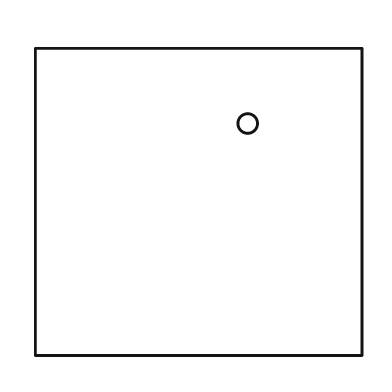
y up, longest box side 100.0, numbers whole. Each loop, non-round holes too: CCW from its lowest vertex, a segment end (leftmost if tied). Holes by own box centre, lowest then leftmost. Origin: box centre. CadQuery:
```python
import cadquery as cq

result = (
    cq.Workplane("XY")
    .moveTo(-50.0, -47.0)
    .lineTo(50.0, -47.0)
    .lineTo(50.0, 47.0)
    .lineTo(-50.0, 47.0)
    .close()
    .moveTo(15.0, 24.0)
    .circle(3.0)
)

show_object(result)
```